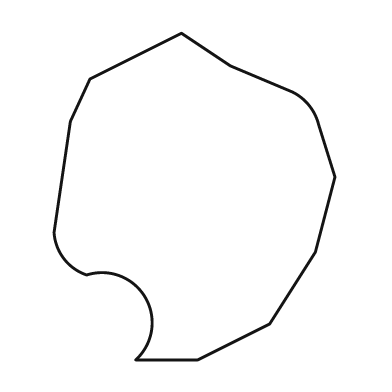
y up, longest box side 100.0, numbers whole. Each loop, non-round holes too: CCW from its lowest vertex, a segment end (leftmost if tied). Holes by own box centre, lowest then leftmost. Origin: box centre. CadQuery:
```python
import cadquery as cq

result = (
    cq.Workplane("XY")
    .moveTo(-18.0, -50.0)
    .lineTo(1.0, -50.0)
    .lineTo(23.0, -39.0)
    .lineTo(37.0, -17.0)
    .lineTo(43.0, 6.0)
    .lineTo(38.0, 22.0)
    .threePointArc((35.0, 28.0), (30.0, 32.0))
    .lineTo(11.0, 40.0)
    .lineTo(-4.0, 50.0)
    .lineTo(-32.0, 36.0)
    .lineTo(-38.0, 23.0)
    .lineTo(-43.0, -11.0)
    .threePointArc((-40.0, -19.0), (-33.0, -24.0))
    .threePointArc((-15.0, -31.0), (-18.0, -50.0))
    .close()
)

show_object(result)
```